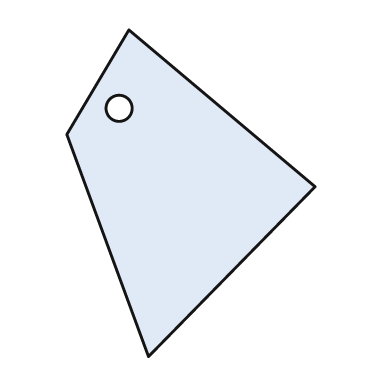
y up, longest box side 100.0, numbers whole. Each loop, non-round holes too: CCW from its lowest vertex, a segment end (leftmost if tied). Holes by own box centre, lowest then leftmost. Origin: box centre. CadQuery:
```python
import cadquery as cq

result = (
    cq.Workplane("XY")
    .moveTo(-13.0, -50.0)
    .lineTo(38.0, 2.0)
    .lineTo(-19.0, 50.0)
    .lineTo(-38.0, 18.0)
    .close()
    .moveTo(-22.0, 26.0)
    .circle(4.0)
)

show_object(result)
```